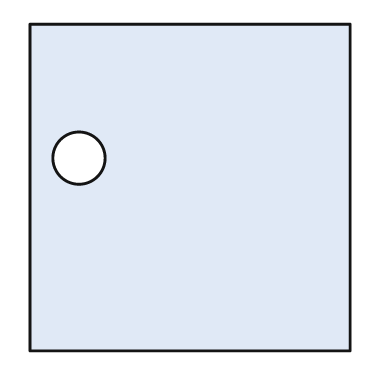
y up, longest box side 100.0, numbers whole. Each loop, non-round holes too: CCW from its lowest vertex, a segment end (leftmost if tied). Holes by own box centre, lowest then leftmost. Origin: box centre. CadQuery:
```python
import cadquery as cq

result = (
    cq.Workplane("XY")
    .moveTo(-49.0, -50.0)
    .lineTo(49.0, -50.0)
    .lineTo(49.0, 50.0)
    .lineTo(-49.0, 50.0)
    .close()
    .moveTo(-34.0, 9.0)
    .circle(8.0)
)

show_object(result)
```